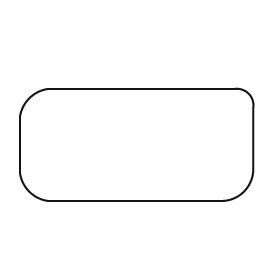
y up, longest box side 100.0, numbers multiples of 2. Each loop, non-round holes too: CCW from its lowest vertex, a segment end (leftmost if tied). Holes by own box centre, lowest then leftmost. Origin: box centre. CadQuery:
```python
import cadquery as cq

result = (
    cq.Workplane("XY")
    .moveTo(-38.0, -24.0)
    .lineTo(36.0, -24.0)
    .threePointArc((46.0, -20.0), (50.0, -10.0))
    .lineTo(50.0, 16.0)
    .threePointArc((48.0, 22.0), (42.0, 24.0))
    .lineTo(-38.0, 24.0)
    .threePointArc((-46.0, 20.0), (-50.0, 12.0))
    .lineTo(-50.0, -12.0)
    .threePointArc((-46.0, -20.0), (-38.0, -24.0))
    .close()
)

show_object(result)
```